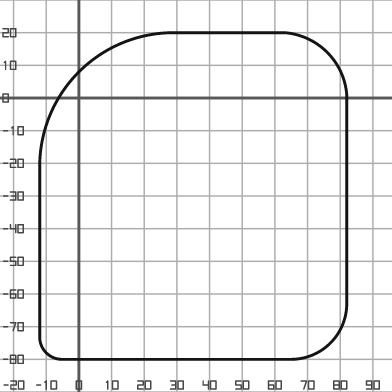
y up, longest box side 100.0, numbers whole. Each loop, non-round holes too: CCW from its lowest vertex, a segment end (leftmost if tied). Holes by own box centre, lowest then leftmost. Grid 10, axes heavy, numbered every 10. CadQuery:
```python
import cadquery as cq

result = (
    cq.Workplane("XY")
    .moveTo(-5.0, -80.0)
    .lineTo(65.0, -80.0)
    .threePointArc((77.0, -75.0), (82.0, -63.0))
    .lineTo(82.0, 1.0)
    .threePointArc((76.0, 14.0), (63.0, 20.0))
    .lineTo(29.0, 20.0)
    .threePointArc((0.0, 8.0), (-12.0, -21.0))
    .lineTo(-12.0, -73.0)
    .threePointArc((-10.0, -78.0), (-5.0, -80.0))
    .close()
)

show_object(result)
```